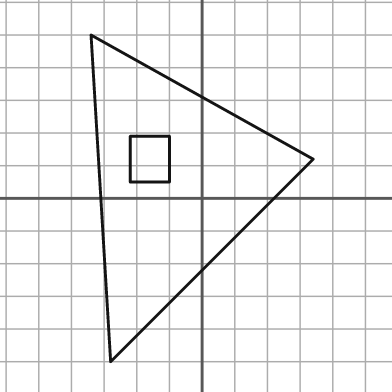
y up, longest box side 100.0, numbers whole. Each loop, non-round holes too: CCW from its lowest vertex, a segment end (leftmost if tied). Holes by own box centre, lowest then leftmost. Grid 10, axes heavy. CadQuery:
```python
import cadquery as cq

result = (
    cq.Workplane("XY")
    .moveTo(-28.0, -50.0)
    .lineTo(34.0, 12.0)
    .lineTo(-34.0, 50.0)
    .close()
    .moveTo(-22.0, 5.0)
    .lineTo(-10.0, 5.0)
    .lineTo(-10.0, 19.0)
    .lineTo(-22.0, 19.0)
    .close()
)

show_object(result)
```